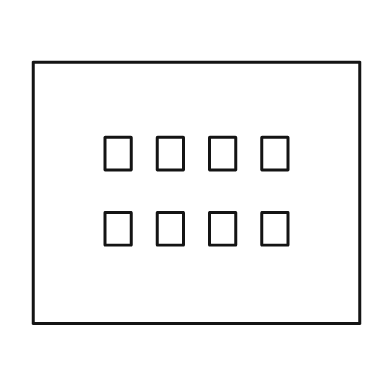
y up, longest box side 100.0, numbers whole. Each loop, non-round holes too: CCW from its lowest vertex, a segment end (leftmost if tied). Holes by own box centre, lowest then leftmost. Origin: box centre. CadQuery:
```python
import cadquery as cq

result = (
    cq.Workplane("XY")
    .moveTo(-50.0, -40.0)
    .lineTo(50.0, -40.0)
    .lineTo(50.0, 40.0)
    .lineTo(-50.0, 40.0)
    .close()
    .moveTo(-28.0, -16.0)
    .lineTo(-20.0, -16.0)
    .lineTo(-20.0, -6.0)
    .lineTo(-28.0, -6.0)
    .close()
    .moveTo(-12.0, -16.0)
    .lineTo(-4.0, -16.0)
    .lineTo(-4.0, -6.0)
    .lineTo(-12.0, -6.0)
    .close()
    .moveTo(4.0, -16.0)
    .lineTo(12.0, -16.0)
    .lineTo(12.0, -6.0)
    .lineTo(4.0, -6.0)
    .close()
    .moveTo(20.0, -16.0)
    .lineTo(28.0, -16.0)
    .lineTo(28.0, -6.0)
    .lineTo(20.0, -6.0)
    .close()
    .moveTo(-28.0, 7.0)
    .lineTo(-20.0, 7.0)
    .lineTo(-20.0, 17.0)
    .lineTo(-28.0, 17.0)
    .close()
    .moveTo(-12.0, 7.0)
    .lineTo(-4.0, 7.0)
    .lineTo(-4.0, 17.0)
    .lineTo(-12.0, 17.0)
    .close()
    .moveTo(4.0, 7.0)
    .lineTo(12.0, 7.0)
    .lineTo(12.0, 17.0)
    .lineTo(4.0, 17.0)
    .close()
    .moveTo(20.0, 7.0)
    .lineTo(28.0, 7.0)
    .lineTo(28.0, 17.0)
    .lineTo(20.0, 17.0)
    .close()
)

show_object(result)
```